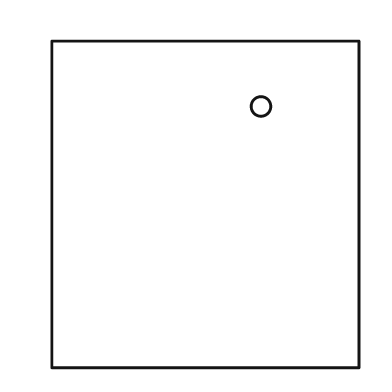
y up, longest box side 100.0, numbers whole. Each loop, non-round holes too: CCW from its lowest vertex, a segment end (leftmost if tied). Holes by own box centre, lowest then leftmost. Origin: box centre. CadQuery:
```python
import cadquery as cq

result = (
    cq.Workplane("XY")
    .moveTo(-47.0, -50.0)
    .lineTo(47.0, -50.0)
    .lineTo(47.0, 50.0)
    .lineTo(-47.0, 50.0)
    .close()
    .moveTo(17.0, 30.0)
    .circle(3.0)
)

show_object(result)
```